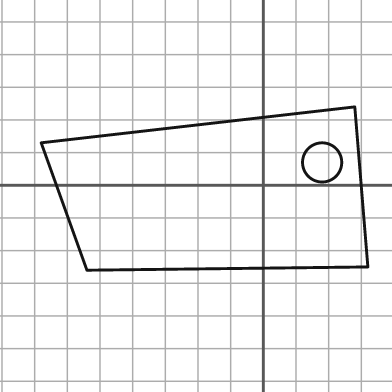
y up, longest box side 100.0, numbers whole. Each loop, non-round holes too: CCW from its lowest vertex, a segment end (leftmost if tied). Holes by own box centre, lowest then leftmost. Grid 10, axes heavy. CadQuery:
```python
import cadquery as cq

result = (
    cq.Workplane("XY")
    .moveTo(-54.0, -26.0)
    .lineTo(32.0, -25.0)
    .lineTo(28.0, 24.0)
    .lineTo(-68.0, 13.0)
    .close()
    .moveTo(18.0, 7.0)
    .circle(6.0)
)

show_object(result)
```